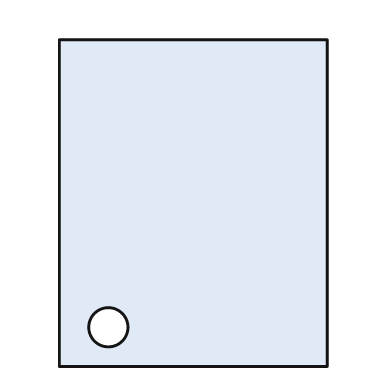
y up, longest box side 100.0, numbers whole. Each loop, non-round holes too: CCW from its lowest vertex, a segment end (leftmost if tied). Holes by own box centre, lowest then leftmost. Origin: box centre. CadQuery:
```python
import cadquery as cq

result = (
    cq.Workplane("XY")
    .moveTo(-41.0, -50.0)
    .lineTo(41.0, -50.0)
    .lineTo(41.0, 50.0)
    .lineTo(-41.0, 50.0)
    .close()
    .moveTo(-26.0, -38.0)
    .circle(6.0)
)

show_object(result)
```